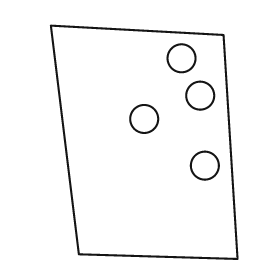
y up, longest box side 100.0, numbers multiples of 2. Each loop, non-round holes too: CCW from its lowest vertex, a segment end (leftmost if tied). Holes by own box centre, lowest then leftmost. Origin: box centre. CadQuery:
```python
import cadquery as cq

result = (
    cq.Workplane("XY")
    .moveTo(40.0, -50.0)
    .lineTo(34.0, 46.0)
    .lineTo(-40.0, 50.0)
    .lineTo(-28.0, -48.0)
    .close()
    .moveTo(26.0, -10.0)
    .circle(6.0)
    .moveTo(0.0, 10.0)
    .circle(6.0)
    .moveTo(24.0, 20.0)
    .circle(6.0)
    .moveTo(16.0, 36.0)
    .circle(6.0)
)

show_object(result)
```